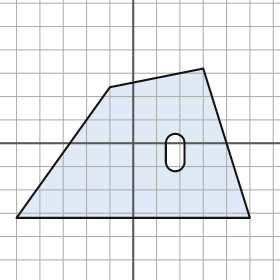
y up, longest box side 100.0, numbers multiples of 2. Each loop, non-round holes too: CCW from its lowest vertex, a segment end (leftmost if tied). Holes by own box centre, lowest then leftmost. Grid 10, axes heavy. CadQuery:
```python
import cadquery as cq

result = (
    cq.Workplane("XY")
    .moveTo(-50.0, -32.0)
    .lineTo(50.0, -32.0)
    .lineTo(30.0, 32.0)
    .lineTo(-10.0, 24.0)
    .close()
    .moveTo(14.0, -8.0)
    .threePointArc((18.0, -12.0), (22.0, -8.0))
    .lineTo(22.0, 0.0)
    .threePointArc((18.0, 4.0), (14.0, 0.0))
    .close()
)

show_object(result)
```